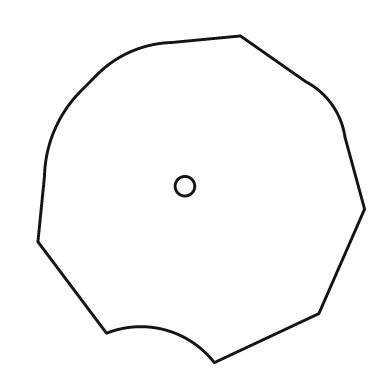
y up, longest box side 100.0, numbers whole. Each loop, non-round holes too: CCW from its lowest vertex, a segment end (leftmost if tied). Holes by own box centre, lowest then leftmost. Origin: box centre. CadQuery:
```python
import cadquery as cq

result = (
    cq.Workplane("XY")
    .moveTo(4.0, -50.0)
    .lineTo(36.0, -35.0)
    .lineTo(50.0, -3.0)
    .lineTo(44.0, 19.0)
    .threePointArc((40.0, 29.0), (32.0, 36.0))
    .lineTo(12.0, 50.0)
    .lineTo(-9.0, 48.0)
    .threePointArc((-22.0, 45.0), (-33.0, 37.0))
    .lineTo(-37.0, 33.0)
    .threePointArc((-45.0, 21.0), (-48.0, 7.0))
    .lineTo(-50.0, -13.0)
    .lineTo(-29.0, -41.0)
    .threePointArc((-11.0, -40.0), (4.0, -50.0))
    .close()
    .moveTo(-5.0, 4.0)
    .circle(3.0)
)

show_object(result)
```